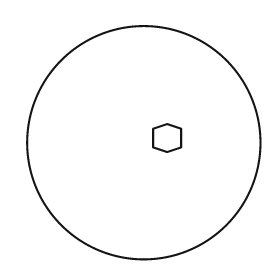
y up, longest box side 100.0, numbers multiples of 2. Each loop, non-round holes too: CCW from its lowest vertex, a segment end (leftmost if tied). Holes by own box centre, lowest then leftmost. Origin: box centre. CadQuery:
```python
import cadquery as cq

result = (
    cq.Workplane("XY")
    .moveTo(0.0, 0.0)
    .circle(50.0)
    .moveTo(10.0, -4.0)
    .lineTo(16.0, -2.0)
    .lineTo(16.0, 6.0)
    .lineTo(10.0, 8.0)
    .lineTo(4.0, 6.0)
    .lineTo(4.0, -2.0)
    .close()
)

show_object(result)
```